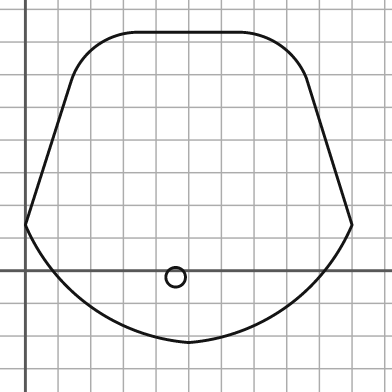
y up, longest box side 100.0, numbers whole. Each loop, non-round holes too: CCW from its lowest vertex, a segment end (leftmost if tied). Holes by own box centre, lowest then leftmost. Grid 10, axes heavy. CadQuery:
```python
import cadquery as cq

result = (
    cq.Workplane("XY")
    .moveTo(50.0, -22.0)
    .threePointArc((80.0, -11.0), (100.0, 14.0))
    .lineTo(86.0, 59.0)
    .threePointArc((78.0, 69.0), (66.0, 73.0))
    .lineTo(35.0, 73.0)
    .threePointArc((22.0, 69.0), (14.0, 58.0))
    .lineTo(0.0, 14.0)
    .threePointArc((20.0, -11.0), (50.0, -22.0))
    .close()
    .moveTo(46.0, -2.0)
    .circle(3.0)
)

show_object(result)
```